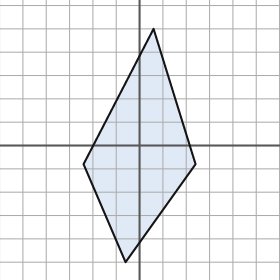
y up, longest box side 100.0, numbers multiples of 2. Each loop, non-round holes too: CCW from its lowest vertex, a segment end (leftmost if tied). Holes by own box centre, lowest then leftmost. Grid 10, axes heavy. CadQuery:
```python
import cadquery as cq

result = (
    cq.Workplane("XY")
    .moveTo(-6.0, -50.0)
    .lineTo(24.0, -8.0)
    .lineTo(6.0, 50.0)
    .lineTo(-24.0, -8.0)
    .close()
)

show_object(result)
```